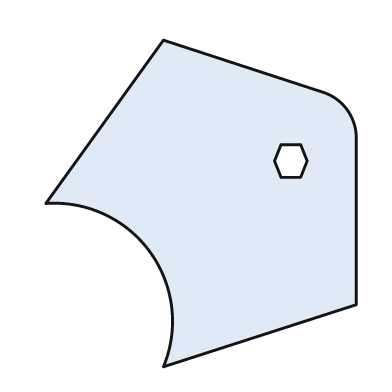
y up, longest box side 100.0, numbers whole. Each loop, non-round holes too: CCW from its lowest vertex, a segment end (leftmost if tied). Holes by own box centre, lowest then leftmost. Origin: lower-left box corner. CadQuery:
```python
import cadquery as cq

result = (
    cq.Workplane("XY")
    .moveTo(36.0, 0.0)
    .lineTo(95.0, 19.0)
    .lineTo(95.0, 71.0)
    .threePointArc((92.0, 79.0), (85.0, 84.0))
    .lineTo(36.0, 100.0)
    .lineTo(0.0, 50.0)
    .threePointArc((32.0, 35.0), (36.0, 0.0))
    .close()
    .moveTo(72.0, 58.0)
    .lineTo(78.0, 58.0)
    .lineTo(80.0, 63.0)
    .lineTo(78.0, 68.0)
    .lineTo(72.0, 68.0)
    .lineTo(70.0, 63.0)
    .close()
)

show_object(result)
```